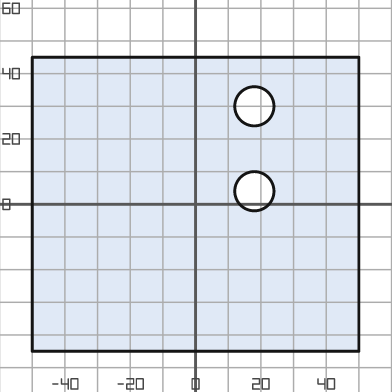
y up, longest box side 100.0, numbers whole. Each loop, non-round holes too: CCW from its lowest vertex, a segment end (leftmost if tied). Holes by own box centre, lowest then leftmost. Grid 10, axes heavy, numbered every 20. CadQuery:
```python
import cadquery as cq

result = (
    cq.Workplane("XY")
    .moveTo(-50.0, -45.0)
    .lineTo(50.0, -45.0)
    .lineTo(50.0, 45.0)
    .lineTo(-50.0, 45.0)
    .close()
    .moveTo(18.0, 4.0)
    .circle(6.0)
    .moveTo(18.0, 30.0)
    .circle(6.0)
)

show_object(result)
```